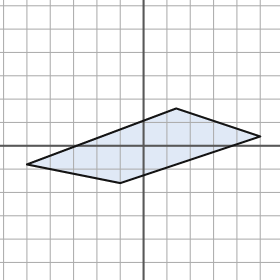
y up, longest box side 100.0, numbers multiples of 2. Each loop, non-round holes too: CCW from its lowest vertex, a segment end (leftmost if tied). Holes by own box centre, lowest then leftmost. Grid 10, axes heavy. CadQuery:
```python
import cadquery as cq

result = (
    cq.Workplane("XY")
    .moveTo(-10.0, -16.0)
    .lineTo(50.0, 4.0)
    .lineTo(14.0, 16.0)
    .lineTo(-50.0, -8.0)
    .close()
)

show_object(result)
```